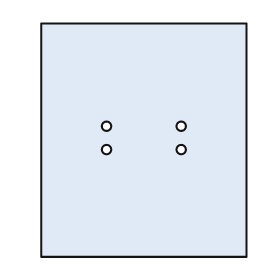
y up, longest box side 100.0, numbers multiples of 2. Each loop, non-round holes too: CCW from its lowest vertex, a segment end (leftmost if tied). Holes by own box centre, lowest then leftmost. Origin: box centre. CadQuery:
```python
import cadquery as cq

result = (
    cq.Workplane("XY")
    .moveTo(-44.0, -50.0)
    .lineTo(44.0, -50.0)
    .lineTo(44.0, 50.0)
    .lineTo(-44.0, 50.0)
    .close()
    .moveTo(-16.0, -4.0)
    .circle(2.0)
    .moveTo(16.0, -4.0)
    .circle(2.0)
    .moveTo(-16.0, 6.0)
    .circle(2.0)
    .moveTo(16.0, 6.0)
    .circle(2.0)
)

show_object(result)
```